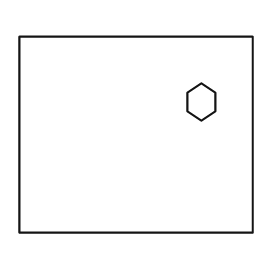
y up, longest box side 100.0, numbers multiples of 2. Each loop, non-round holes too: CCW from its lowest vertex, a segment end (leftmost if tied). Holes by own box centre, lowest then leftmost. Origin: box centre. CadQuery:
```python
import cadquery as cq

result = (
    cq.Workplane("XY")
    .moveTo(-50.0, -42.0)
    .lineTo(50.0, -42.0)
    .lineTo(50.0, 42.0)
    .lineTo(-50.0, 42.0)
    .close()
    .moveTo(28.0, 6.0)
    .lineTo(34.0, 10.0)
    .lineTo(34.0, 18.0)
    .lineTo(28.0, 22.0)
    .lineTo(22.0, 18.0)
    .lineTo(22.0, 10.0)
    .close()
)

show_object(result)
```